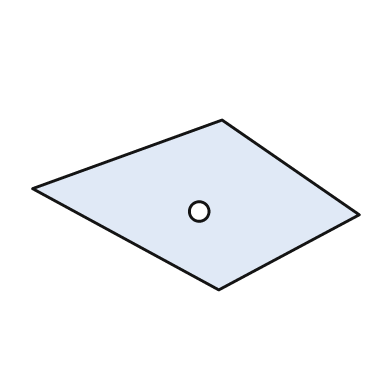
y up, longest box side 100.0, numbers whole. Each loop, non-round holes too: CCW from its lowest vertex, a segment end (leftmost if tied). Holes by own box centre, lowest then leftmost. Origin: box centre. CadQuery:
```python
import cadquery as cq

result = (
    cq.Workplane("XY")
    .moveTo(7.0, -26.0)
    .lineTo(50.0, -3.0)
    .lineTo(8.0, 26.0)
    .lineTo(-50.0, 5.0)
    .close()
    .moveTo(1.0, -2.0)
    .circle(3.0)
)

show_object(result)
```